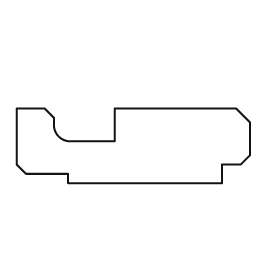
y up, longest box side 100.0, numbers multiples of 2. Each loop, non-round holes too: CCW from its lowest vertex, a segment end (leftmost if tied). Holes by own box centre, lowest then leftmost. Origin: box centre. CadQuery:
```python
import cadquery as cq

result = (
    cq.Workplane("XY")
    .moveTo(-28.0, -16.0)
    .lineTo(38.0, -16.0)
    .lineTo(38.0, -8.0)
    .lineTo(46.0, -8.0)
    .lineTo(50.0, -4.0)
    .lineTo(50.0, 10.0)
    .lineTo(44.0, 16.0)
    .lineTo(-8.0, 16.0)
    .lineTo(-8.0, 2.0)
    .lineTo(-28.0, 2.0)
    .threePointArc((-32.0, 4.0), (-34.0, 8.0))
    .lineTo(-34.0, 12.0)
    .lineTo(-38.0, 16.0)
    .lineTo(-50.0, 16.0)
    .lineTo(-50.0, -8.0)
    .lineTo(-46.0, -12.0)
    .lineTo(-28.0, -12.0)
    .close()
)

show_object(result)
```